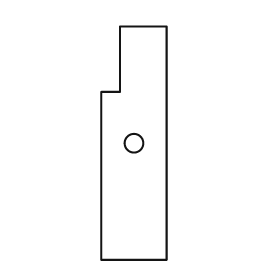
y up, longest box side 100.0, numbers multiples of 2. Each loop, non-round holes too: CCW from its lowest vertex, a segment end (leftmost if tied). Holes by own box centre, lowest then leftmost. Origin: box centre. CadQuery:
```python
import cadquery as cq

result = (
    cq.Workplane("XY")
    .moveTo(-14.0, -50.0)
    .lineTo(14.0, -50.0)
    .lineTo(14.0, 50.0)
    .lineTo(-6.0, 50.0)
    .lineTo(-6.0, 22.0)
    .lineTo(-14.0, 22.0)
    .close()
    .moveTo(0.0, 0.0)
    .circle(4.0)
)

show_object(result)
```